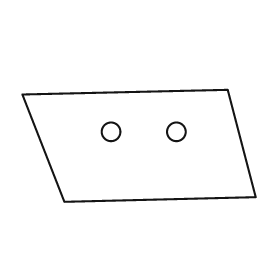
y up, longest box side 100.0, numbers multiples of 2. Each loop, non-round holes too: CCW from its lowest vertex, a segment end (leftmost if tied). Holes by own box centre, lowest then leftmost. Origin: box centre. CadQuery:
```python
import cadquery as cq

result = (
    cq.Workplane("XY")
    .moveTo(-32.0, -24.0)
    .lineTo(50.0, -22.0)
    .lineTo(38.0, 24.0)
    .lineTo(-50.0, 22.0)
    .close()
    .moveTo(-12.0, 6.0)
    .circle(4.0)
    .moveTo(16.0, 6.0)
    .circle(4.0)
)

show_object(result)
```